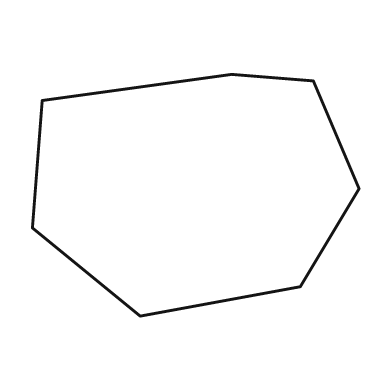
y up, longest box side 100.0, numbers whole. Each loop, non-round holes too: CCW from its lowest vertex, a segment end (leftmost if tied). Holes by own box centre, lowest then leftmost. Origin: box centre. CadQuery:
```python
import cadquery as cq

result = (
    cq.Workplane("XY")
    .moveTo(-17.0, -37.0)
    .lineTo(32.0, -28.0)
    .lineTo(50.0, 2.0)
    .lineTo(36.0, 35.0)
    .lineTo(11.0, 37.0)
    .lineTo(-47.0, 29.0)
    .lineTo(-50.0, -10.0)
    .close()
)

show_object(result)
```